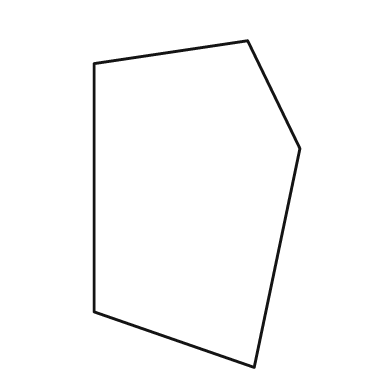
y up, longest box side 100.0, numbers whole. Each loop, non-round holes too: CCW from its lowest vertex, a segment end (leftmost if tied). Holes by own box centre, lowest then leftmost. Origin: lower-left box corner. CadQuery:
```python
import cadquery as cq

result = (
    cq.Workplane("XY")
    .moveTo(49.0, 0.0)
    .lineTo(63.0, 67.0)
    .lineTo(47.0, 100.0)
    .lineTo(0.0, 93.0)
    .lineTo(0.0, 17.0)
    .close()
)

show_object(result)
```